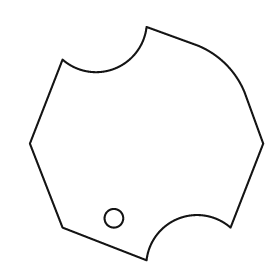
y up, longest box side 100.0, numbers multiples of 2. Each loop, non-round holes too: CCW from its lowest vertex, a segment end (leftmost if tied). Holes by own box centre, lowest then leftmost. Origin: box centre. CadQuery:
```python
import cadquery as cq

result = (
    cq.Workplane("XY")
    .moveTo(0.0, -50.0)
    .threePointArc((14.0, -32.0), (36.0, -36.0))
    .lineTo(50.0, 0.0)
    .lineTo(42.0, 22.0)
    .threePointArc((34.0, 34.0), (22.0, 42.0))
    .lineTo(0.0, 50.0)
    .threePointArc((-14.0, 32.0), (-36.0, 36.0))
    .lineTo(-50.0, 0.0)
    .lineTo(-36.0, -36.0)
    .close()
    .moveTo(-14.0, -32.0)
    .circle(4.0)
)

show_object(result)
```